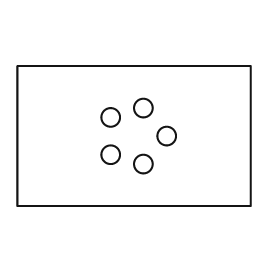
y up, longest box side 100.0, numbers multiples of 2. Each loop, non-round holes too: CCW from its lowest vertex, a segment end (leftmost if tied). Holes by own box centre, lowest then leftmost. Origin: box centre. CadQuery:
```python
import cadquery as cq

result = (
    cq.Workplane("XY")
    .moveTo(-50.0, -30.0)
    .lineTo(50.0, -30.0)
    .lineTo(50.0, 30.0)
    .lineTo(-50.0, 30.0)
    .close()
    .moveTo(4.0, -12.0)
    .circle(4.0)
    .moveTo(-10.0, -8.0)
    .circle(4.0)
    .moveTo(14.0, 0.0)
    .circle(4.0)
    .moveTo(-10.0, 8.0)
    .circle(4.0)
    .moveTo(4.0, 12.0)
    .circle(4.0)
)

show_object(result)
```